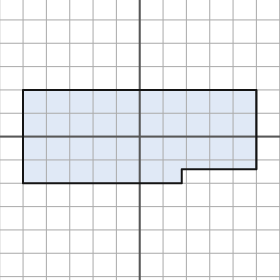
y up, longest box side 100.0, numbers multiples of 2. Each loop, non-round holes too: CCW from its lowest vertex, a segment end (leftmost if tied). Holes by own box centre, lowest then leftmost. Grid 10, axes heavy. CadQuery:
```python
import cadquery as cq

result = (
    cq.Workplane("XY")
    .moveTo(-50.0, -20.0)
    .lineTo(18.0, -20.0)
    .lineTo(18.0, -14.0)
    .lineTo(50.0, -14.0)
    .lineTo(50.0, 20.0)
    .lineTo(-50.0, 20.0)
    .close()
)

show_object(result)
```